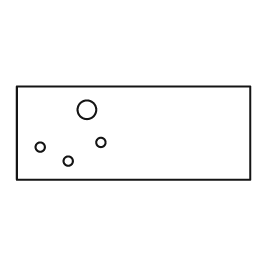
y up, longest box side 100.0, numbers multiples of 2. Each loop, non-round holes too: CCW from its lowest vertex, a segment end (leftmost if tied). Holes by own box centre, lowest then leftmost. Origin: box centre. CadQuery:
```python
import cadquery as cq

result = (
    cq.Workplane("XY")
    .moveTo(-50.0, -20.0)
    .lineTo(50.0, -20.0)
    .lineTo(50.0, 20.0)
    .lineTo(-50.0, 20.0)
    .close()
    .moveTo(-28.0, -12.0)
    .circle(2.0)
    .moveTo(-40.0, -6.0)
    .circle(2.0)
    .moveTo(-14.0, -4.0)
    .circle(2.0)
    .moveTo(-20.0, 10.0)
    .circle(4.0)
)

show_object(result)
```